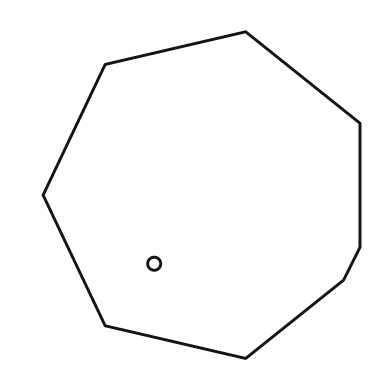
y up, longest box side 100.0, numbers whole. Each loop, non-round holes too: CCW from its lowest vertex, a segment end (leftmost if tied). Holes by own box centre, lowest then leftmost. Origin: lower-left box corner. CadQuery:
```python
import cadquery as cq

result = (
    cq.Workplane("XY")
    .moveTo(62.0, 0.0)
    .lineTo(92.0, 24.0)
    .lineTo(97.0, 34.0)
    .lineTo(97.0, 72.0)
    .lineTo(62.0, 100.0)
    .lineTo(19.0, 90.0)
    .lineTo(0.0, 50.0)
    .lineTo(19.0, 10.0)
    .close()
    .moveTo(34.0, 29.0)
    .circle(2.0)
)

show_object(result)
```